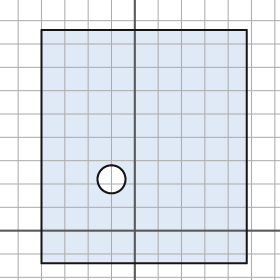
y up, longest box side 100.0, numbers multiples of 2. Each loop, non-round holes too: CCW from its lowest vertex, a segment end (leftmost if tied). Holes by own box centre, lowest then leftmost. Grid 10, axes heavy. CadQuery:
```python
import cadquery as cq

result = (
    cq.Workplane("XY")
    .moveTo(-40.0, -14.0)
    .lineTo(48.0, -14.0)
    .lineTo(48.0, 86.0)
    .lineTo(-40.0, 86.0)
    .close()
    .moveTo(-10.0, 22.0)
    .circle(6.0)
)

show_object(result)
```